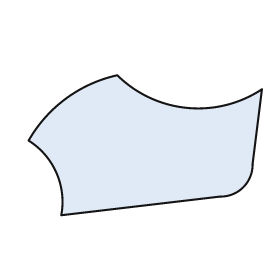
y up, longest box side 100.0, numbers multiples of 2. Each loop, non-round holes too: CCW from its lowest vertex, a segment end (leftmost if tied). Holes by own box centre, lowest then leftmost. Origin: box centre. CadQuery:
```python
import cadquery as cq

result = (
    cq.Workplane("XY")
    .moveTo(-36.0, -30.0)
    .lineTo(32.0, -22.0)
    .threePointArc((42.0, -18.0), (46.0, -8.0))
    .lineTo(50.0, 24.0)
    .threePointArc((18.0, 16.0), (-12.0, 30.0))
    .threePointArc((-34.0, 20.0), (-50.0, 2.0))
    .threePointArc((-38.0, -12.0), (-36.0, -30.0))
    .close()
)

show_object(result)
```